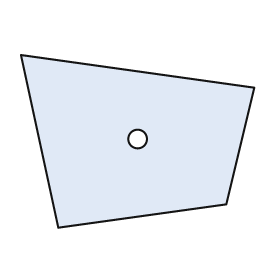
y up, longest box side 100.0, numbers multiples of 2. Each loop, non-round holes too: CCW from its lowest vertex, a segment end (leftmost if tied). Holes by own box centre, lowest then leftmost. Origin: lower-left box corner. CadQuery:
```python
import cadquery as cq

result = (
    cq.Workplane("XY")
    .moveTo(16.0, 0.0)
    .lineTo(88.0, 10.0)
    .lineTo(100.0, 60.0)
    .lineTo(0.0, 74.0)
    .close()
    .moveTo(50.0, 38.0)
    .circle(4.0)
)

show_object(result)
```